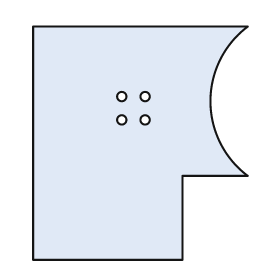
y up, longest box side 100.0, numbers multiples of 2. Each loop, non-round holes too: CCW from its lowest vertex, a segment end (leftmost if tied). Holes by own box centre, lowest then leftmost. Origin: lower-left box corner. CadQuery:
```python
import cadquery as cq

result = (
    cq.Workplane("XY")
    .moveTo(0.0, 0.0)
    .lineTo(64.0, 0.0)
    .lineTo(64.0, 36.0)
    .lineTo(92.0, 36.0)
    .threePointArc((76.0, 68.0), (92.0, 100.0))
    .lineTo(0.0, 100.0)
    .close()
    .moveTo(38.0, 60.0)
    .circle(2.0)
    .moveTo(48.0, 60.0)
    .circle(2.0)
    .moveTo(38.0, 70.0)
    .circle(2.0)
    .moveTo(48.0, 70.0)
    .circle(2.0)
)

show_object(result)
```